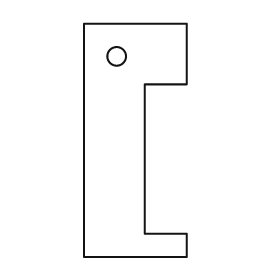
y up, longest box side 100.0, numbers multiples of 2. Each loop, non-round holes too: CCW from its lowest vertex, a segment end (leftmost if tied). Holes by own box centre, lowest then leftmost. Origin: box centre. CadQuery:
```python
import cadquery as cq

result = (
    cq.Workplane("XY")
    .moveTo(-22.0, -50.0)
    .lineTo(22.0, -50.0)
    .lineTo(22.0, -40.0)
    .lineTo(4.0, -40.0)
    .lineTo(4.0, 24.0)
    .lineTo(22.0, 24.0)
    .lineTo(22.0, 50.0)
    .lineTo(-22.0, 50.0)
    .close()
    .moveTo(-8.0, 36.0)
    .circle(4.0)
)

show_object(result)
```